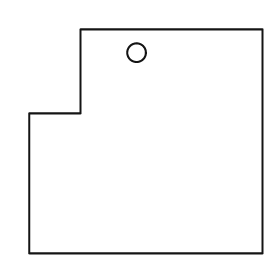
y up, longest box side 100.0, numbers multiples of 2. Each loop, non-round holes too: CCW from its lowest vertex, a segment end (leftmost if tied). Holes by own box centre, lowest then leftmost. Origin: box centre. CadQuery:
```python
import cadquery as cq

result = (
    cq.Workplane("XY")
    .moveTo(-50.0, -48.0)
    .lineTo(50.0, -48.0)
    .lineTo(50.0, 48.0)
    .lineTo(-28.0, 48.0)
    .lineTo(-28.0, 12.0)
    .lineTo(-50.0, 12.0)
    .close()
    .moveTo(-4.0, 38.0)
    .circle(4.0)
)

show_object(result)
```